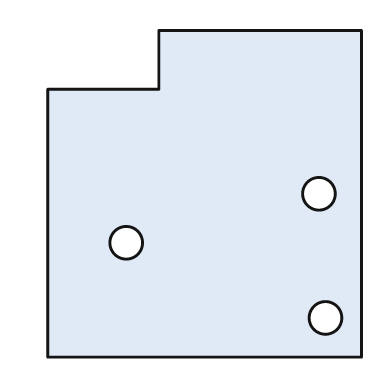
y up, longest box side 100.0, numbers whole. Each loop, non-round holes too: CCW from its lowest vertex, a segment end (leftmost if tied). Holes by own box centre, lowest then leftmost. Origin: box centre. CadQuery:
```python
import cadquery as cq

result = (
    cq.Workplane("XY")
    .moveTo(-48.0, -50.0)
    .lineTo(48.0, -50.0)
    .lineTo(48.0, 50.0)
    .lineTo(-14.0, 50.0)
    .lineTo(-14.0, 32.0)
    .lineTo(-48.0, 32.0)
    .close()
    .moveTo(37.0, -38.0)
    .circle(5.0)
    .moveTo(-24.0, -15.0)
    .circle(5.0)
    .moveTo(35.0, 0.0)
    .circle(5.0)
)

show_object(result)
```